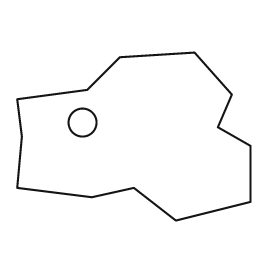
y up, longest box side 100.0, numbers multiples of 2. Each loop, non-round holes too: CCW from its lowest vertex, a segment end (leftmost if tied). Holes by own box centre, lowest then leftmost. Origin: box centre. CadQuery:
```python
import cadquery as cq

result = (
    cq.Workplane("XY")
    .moveTo(18.0, -36.0)
    .lineTo(50.0, -28.0)
    .lineTo(50.0, -4.0)
    .lineTo(36.0, 4.0)
    .lineTo(42.0, 18.0)
    .lineTo(26.0, 36.0)
    .lineTo(-6.0, 34.0)
    .lineTo(-20.0, 20.0)
    .lineTo(-50.0, 16.0)
    .lineTo(-48.0, 0.0)
    .lineTo(-50.0, -22.0)
    .lineTo(-18.0, -26.0)
    .lineTo(0.0, -22.0)
    .close()
    .moveTo(-22.0, 6.0)
    .circle(6.0)
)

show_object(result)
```